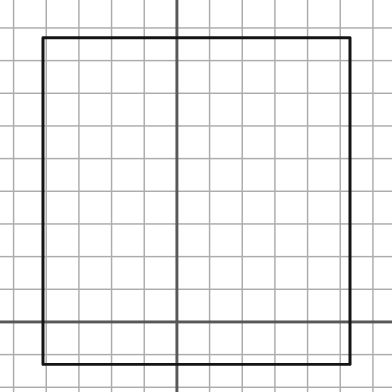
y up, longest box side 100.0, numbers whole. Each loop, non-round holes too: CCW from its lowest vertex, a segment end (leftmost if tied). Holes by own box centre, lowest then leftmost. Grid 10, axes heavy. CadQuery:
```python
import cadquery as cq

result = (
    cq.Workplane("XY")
    .moveTo(-41.0, -13.0)
    .lineTo(53.0, -13.0)
    .lineTo(53.0, 87.0)
    .lineTo(-41.0, 87.0)
    .close()
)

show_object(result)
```